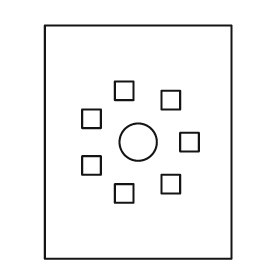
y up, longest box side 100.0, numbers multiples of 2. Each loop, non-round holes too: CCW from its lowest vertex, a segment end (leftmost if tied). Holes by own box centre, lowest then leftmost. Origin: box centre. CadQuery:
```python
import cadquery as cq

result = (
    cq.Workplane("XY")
    .moveTo(-40.0, -50.0)
    .lineTo(40.0, -50.0)
    .lineTo(40.0, 50.0)
    .lineTo(-40.0, 50.0)
    .close()
    .moveTo(-10.0, -26.0)
    .lineTo(-2.0, -26.0)
    .lineTo(-2.0, -18.0)
    .lineTo(-10.0, -18.0)
    .close()
    .moveTo(10.0, -22.0)
    .lineTo(18.0, -22.0)
    .lineTo(18.0, -14.0)
    .lineTo(10.0, -14.0)
    .close()
    .moveTo(-24.0, -14.0)
    .lineTo(-16.0, -14.0)
    .lineTo(-16.0, -6.0)
    .lineTo(-24.0, -6.0)
    .close()
    .moveTo(0.0, 0.0)
    .circle(8.0)
    .moveTo(18.0, -4.0)
    .lineTo(26.0, -4.0)
    .lineTo(26.0, 4.0)
    .lineTo(18.0, 4.0)
    .close()
    .moveTo(-24.0, 6.0)
    .lineTo(-16.0, 6.0)
    .lineTo(-16.0, 14.0)
    .lineTo(-24.0, 14.0)
    .close()
    .moveTo(10.0, 14.0)
    .lineTo(18.0, 14.0)
    .lineTo(18.0, 22.0)
    .lineTo(10.0, 22.0)
    .close()
    .moveTo(-10.0, 18.0)
    .lineTo(-2.0, 18.0)
    .lineTo(-2.0, 26.0)
    .lineTo(-10.0, 26.0)
    .close()
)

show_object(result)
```